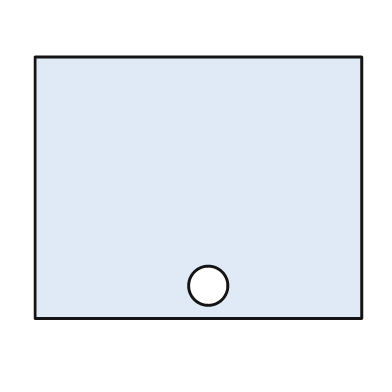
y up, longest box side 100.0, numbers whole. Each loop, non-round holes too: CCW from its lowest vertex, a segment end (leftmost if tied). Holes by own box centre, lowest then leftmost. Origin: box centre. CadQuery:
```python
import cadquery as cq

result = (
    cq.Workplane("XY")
    .moveTo(-50.0, -40.0)
    .lineTo(50.0, -40.0)
    .lineTo(50.0, 40.0)
    .lineTo(-50.0, 40.0)
    .close()
    .moveTo(3.0, -30.0)
    .circle(6.0)
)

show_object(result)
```